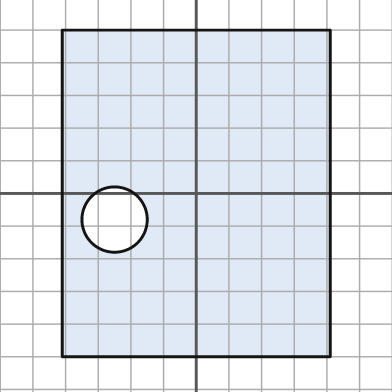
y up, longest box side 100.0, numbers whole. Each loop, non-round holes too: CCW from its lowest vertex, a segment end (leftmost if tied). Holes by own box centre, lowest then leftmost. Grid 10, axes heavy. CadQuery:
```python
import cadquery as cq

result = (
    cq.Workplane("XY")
    .moveTo(-41.0, -50.0)
    .lineTo(41.0, -50.0)
    .lineTo(41.0, 50.0)
    .lineTo(-41.0, 50.0)
    .close()
    .moveTo(-25.0, -8.0)
    .circle(10.0)
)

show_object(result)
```